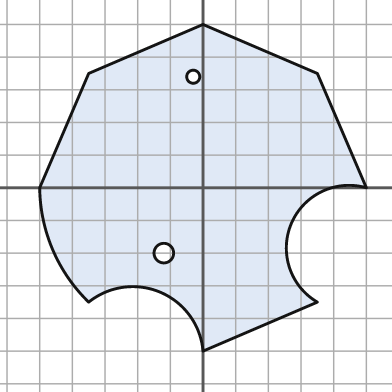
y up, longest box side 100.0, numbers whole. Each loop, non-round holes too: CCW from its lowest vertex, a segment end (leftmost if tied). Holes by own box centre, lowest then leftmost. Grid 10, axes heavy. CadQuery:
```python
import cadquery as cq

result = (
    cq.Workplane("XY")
    .moveTo(0.0, -50.0)
    .lineTo(35.0, -35.0)
    .threePointArc((27.0, -11.0), (50.0, 0.0))
    .lineTo(35.0, 35.0)
    .lineTo(0.0, 50.0)
    .lineTo(-35.0, 35.0)
    .lineTo(-50.0, 0.0)
    .threePointArc((-46.0, -19.0), (-35.0, -35.0))
    .threePointArc((-13.0, -32.0), (0.0, -50.0))
    .close()
    .moveTo(-12.0, -20.0)
    .circle(3.0)
    .moveTo(-3.0, 34.0)
    .circle(2.0)
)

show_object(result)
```